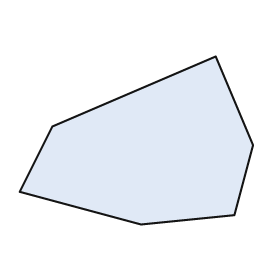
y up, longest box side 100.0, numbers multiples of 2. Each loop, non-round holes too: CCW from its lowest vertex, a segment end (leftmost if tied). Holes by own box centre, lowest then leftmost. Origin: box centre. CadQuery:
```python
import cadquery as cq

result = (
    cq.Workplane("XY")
    .moveTo(2.0, -36.0)
    .lineTo(42.0, -32.0)
    .lineTo(50.0, -2.0)
    .lineTo(34.0, 36.0)
    .lineTo(-36.0, 6.0)
    .lineTo(-50.0, -22.0)
    .close()
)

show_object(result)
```